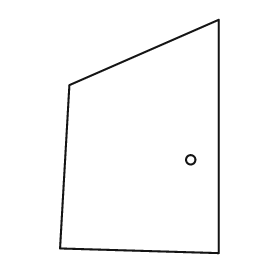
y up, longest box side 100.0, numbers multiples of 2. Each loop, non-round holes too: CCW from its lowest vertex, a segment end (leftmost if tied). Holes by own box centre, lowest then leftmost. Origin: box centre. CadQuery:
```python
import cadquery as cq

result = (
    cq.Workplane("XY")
    .moveTo(34.0, -50.0)
    .lineTo(34.0, 50.0)
    .lineTo(-30.0, 22.0)
    .lineTo(-34.0, -48.0)
    .close()
    .moveTo(22.0, -10.0)
    .circle(2.0)
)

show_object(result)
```